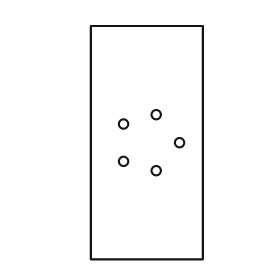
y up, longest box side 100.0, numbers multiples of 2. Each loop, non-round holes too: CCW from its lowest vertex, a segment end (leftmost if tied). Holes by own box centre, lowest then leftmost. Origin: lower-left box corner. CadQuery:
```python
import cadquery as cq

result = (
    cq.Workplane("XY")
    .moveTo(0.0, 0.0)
    .lineTo(48.0, 0.0)
    .lineTo(48.0, 100.0)
    .lineTo(0.0, 100.0)
    .close()
    .moveTo(28.0, 38.0)
    .circle(2.0)
    .moveTo(14.0, 42.0)
    .circle(2.0)
    .moveTo(38.0, 50.0)
    .circle(2.0)
    .moveTo(14.0, 58.0)
    .circle(2.0)
    .moveTo(28.0, 62.0)
    .circle(2.0)
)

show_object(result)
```